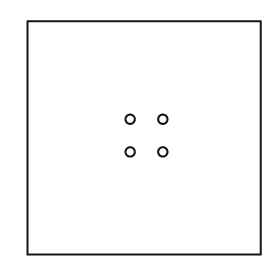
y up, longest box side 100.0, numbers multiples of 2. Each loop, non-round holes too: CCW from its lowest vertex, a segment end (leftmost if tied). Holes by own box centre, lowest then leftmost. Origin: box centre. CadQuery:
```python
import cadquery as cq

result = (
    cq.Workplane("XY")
    .moveTo(-50.0, -50.0)
    .lineTo(50.0, -50.0)
    .lineTo(50.0, 50.0)
    .lineTo(-50.0, 50.0)
    .close()
    .moveTo(-6.0, -6.0)
    .circle(2.0)
    .moveTo(8.0, -6.0)
    .circle(2.0)
    .moveTo(-6.0, 8.0)
    .circle(2.0)
    .moveTo(8.0, 8.0)
    .circle(2.0)
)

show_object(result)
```